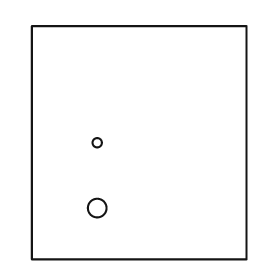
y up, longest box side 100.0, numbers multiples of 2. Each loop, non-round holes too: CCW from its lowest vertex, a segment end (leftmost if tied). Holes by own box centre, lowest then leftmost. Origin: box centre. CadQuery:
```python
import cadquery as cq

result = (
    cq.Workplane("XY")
    .moveTo(-46.0, -50.0)
    .lineTo(46.0, -50.0)
    .lineTo(46.0, 50.0)
    .lineTo(-46.0, 50.0)
    .close()
    .moveTo(-18.0, -28.0)
    .circle(4.0)
    .moveTo(-18.0, 0.0)
    .circle(2.0)
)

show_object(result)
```